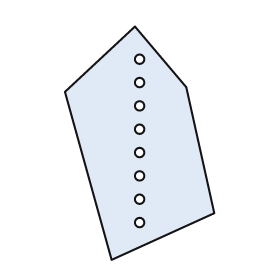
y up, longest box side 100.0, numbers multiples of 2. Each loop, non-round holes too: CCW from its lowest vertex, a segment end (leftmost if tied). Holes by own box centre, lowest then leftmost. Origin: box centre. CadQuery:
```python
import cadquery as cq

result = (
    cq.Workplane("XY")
    .moveTo(-12.0, -50.0)
    .lineTo(32.0, -30.0)
    .lineTo(20.0, 24.0)
    .lineTo(-2.0, 50.0)
    .lineTo(-32.0, 22.0)
    .close()
    .moveTo(0.0, -34.0)
    .circle(2.0)
    .moveTo(0.0, -24.0)
    .circle(2.0)
    .moveTo(0.0, -14.0)
    .circle(2.0)
    .moveTo(0.0, -4.0)
    .circle(2.0)
    .moveTo(0.0, 6.0)
    .circle(2.0)
    .moveTo(0.0, 16.0)
    .circle(2.0)
    .moveTo(0.0, 26.0)
    .circle(2.0)
    .moveTo(0.0, 36.0)
    .circle(2.0)
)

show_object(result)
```